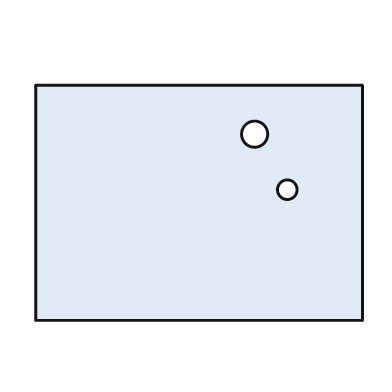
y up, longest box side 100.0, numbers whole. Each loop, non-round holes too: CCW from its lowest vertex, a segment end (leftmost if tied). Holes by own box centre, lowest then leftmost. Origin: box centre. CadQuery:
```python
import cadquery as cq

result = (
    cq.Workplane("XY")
    .moveTo(-50.0, -36.0)
    .lineTo(50.0, -36.0)
    .lineTo(50.0, 36.0)
    .lineTo(-50.0, 36.0)
    .close()
    .moveTo(27.0, 4.0)
    .circle(3.0)
    .moveTo(17.0, 21.0)
    .circle(4.0)
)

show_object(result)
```